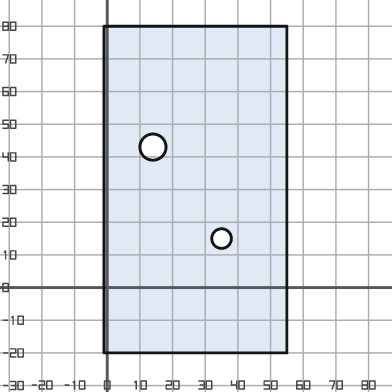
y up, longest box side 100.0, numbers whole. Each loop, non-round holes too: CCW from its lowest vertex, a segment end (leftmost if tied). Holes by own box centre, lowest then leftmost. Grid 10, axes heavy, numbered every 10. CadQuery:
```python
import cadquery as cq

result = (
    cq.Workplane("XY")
    .moveTo(-1.0, -20.0)
    .lineTo(55.0, -20.0)
    .lineTo(55.0, 80.0)
    .lineTo(-1.0, 80.0)
    .close()
    .moveTo(35.0, 15.0)
    .circle(3.0)
    .moveTo(14.0, 43.0)
    .circle(4.0)
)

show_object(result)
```